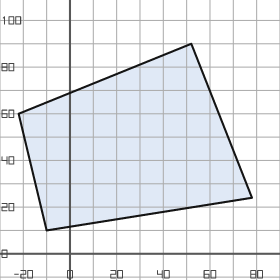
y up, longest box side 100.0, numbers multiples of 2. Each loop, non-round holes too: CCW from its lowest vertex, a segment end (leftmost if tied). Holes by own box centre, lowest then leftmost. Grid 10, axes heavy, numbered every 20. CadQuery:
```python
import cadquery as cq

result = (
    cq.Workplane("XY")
    .moveTo(-10.0, 10.0)
    .lineTo(78.0, 24.0)
    .lineTo(52.0, 90.0)
    .lineTo(-22.0, 60.0)
    .close()
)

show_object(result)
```